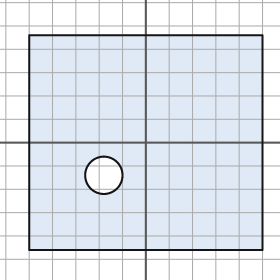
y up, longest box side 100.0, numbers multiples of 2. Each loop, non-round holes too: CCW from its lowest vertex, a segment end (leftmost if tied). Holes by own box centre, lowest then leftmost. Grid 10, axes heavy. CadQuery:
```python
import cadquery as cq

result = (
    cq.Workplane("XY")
    .moveTo(-50.0, -46.0)
    .lineTo(50.0, -46.0)
    .lineTo(50.0, 46.0)
    .lineTo(-50.0, 46.0)
    .close()
    .moveTo(-18.0, -14.0)
    .circle(8.0)
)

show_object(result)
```